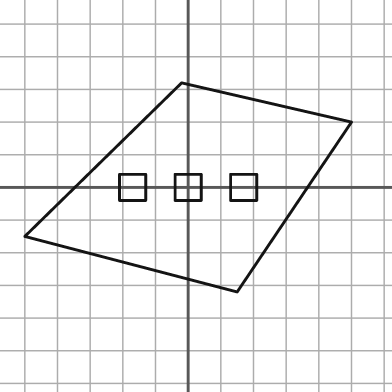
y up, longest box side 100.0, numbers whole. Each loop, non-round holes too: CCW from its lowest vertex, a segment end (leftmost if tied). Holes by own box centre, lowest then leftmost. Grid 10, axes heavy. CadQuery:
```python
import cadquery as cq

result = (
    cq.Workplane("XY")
    .moveTo(15.0, -32.0)
    .lineTo(50.0, 20.0)
    .lineTo(-2.0, 32.0)
    .lineTo(-50.0, -15.0)
    .close()
    .moveTo(-21.0, -4.0)
    .lineTo(-13.0, -4.0)
    .lineTo(-13.0, 4.0)
    .lineTo(-21.0, 4.0)
    .close()
    .moveTo(-4.0, -4.0)
    .lineTo(4.0, -4.0)
    .lineTo(4.0, 4.0)
    .lineTo(-4.0, 4.0)
    .close()
    .moveTo(13.0, -4.0)
    .lineTo(21.0, -4.0)
    .lineTo(21.0, 4.0)
    .lineTo(13.0, 4.0)
    .close()
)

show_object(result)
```